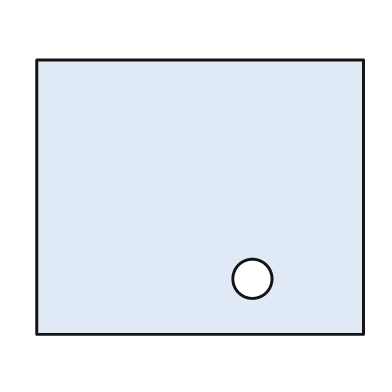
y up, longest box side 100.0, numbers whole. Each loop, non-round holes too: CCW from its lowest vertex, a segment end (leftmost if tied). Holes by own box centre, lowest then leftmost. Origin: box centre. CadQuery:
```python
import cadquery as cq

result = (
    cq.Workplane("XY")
    .moveTo(-50.0, -42.0)
    .lineTo(50.0, -42.0)
    .lineTo(50.0, 42.0)
    .lineTo(-50.0, 42.0)
    .close()
    .moveTo(16.0, -25.0)
    .circle(6.0)
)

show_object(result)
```